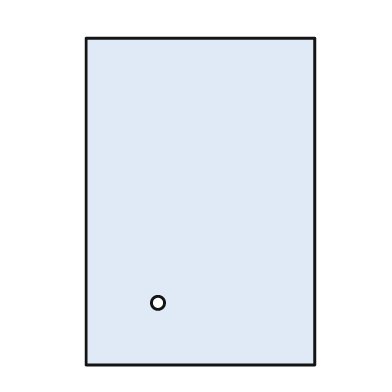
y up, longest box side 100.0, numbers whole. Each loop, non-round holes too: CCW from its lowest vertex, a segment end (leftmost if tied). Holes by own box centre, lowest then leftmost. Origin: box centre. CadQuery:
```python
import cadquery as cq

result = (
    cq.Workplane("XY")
    .moveTo(-35.0, -50.0)
    .lineTo(35.0, -50.0)
    .lineTo(35.0, 50.0)
    .lineTo(-35.0, 50.0)
    .close()
    .moveTo(-13.0, -31.0)
    .circle(2.0)
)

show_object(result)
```